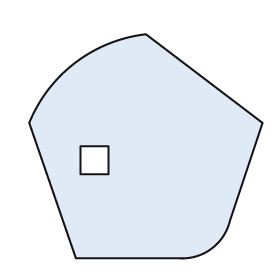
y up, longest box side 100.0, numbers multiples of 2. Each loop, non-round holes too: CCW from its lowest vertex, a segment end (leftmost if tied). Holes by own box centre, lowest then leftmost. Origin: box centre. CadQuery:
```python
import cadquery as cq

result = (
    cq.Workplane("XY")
    .moveTo(-30.0, -48.0)
    .lineTo(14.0, -48.0)
    .threePointArc((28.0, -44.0), (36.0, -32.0))
    .lineTo(50.0, 10.0)
    .lineTo(0.0, 48.0)
    .threePointArc((-30.0, 36.0), (-50.0, 10.0))
    .close()
    .moveTo(-28.0, -12.0)
    .lineTo(-16.0, -12.0)
    .lineTo(-16.0, 0.0)
    .lineTo(-28.0, 0.0)
    .close()
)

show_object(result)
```